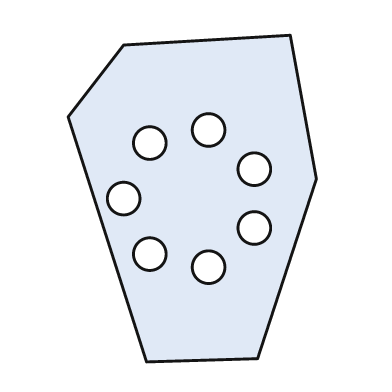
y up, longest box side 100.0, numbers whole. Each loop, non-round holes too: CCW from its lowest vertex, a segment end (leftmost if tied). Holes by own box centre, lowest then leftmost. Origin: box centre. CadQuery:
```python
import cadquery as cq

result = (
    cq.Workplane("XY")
    .moveTo(-14.0, -50.0)
    .lineTo(20.0, -49.0)
    .lineTo(38.0, 6.0)
    .lineTo(30.0, 50.0)
    .lineTo(-21.0, 47.0)
    .lineTo(-38.0, 25.0)
    .close()
    .moveTo(5.0, -21.0)
    .circle(5.0)
    .moveTo(-13.0, -17.0)
    .circle(5.0)
    .moveTo(19.0, -9.0)
    .circle(5.0)
    .moveTo(-21.0, 0.0)
    .circle(5.0)
    .moveTo(19.0, 9.0)
    .circle(5.0)
    .moveTo(-13.0, 17.0)
    .circle(5.0)
    .moveTo(5.0, 21.0)
    .circle(5.0)
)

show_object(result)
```